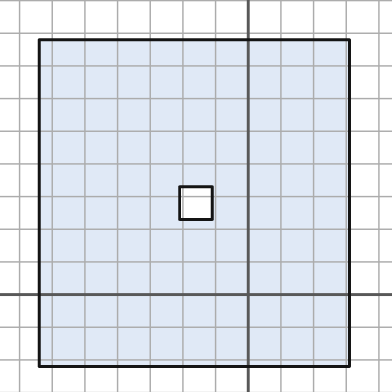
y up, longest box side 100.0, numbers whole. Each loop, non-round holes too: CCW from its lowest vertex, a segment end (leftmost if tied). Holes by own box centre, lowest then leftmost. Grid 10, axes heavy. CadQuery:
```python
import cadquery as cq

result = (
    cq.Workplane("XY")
    .moveTo(-64.0, -22.0)
    .lineTo(31.0, -22.0)
    .lineTo(31.0, 78.0)
    .lineTo(-64.0, 78.0)
    .close()
    .moveTo(-21.0, 23.0)
    .lineTo(-11.0, 23.0)
    .lineTo(-11.0, 33.0)
    .lineTo(-21.0, 33.0)
    .close()
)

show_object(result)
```